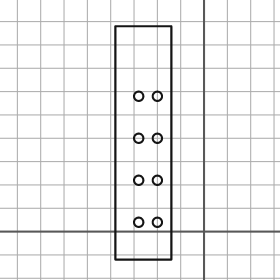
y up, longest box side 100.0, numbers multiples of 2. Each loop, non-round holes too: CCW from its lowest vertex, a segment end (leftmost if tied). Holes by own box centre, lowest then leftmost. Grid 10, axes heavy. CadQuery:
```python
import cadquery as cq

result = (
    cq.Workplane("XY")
    .moveTo(-38.0, -12.0)
    .lineTo(-14.0, -12.0)
    .lineTo(-14.0, 88.0)
    .lineTo(-38.0, 88.0)
    .close()
    .moveTo(-28.0, 4.0)
    .circle(2.0)
    .moveTo(-20.0, 4.0)
    .circle(2.0)
    .moveTo(-28.0, 22.0)
    .circle(2.0)
    .moveTo(-20.0, 22.0)
    .circle(2.0)
    .moveTo(-28.0, 40.0)
    .circle(2.0)
    .moveTo(-20.0, 40.0)
    .circle(2.0)
    .moveTo(-28.0, 58.0)
    .circle(2.0)
    .moveTo(-20.0, 58.0)
    .circle(2.0)
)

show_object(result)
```